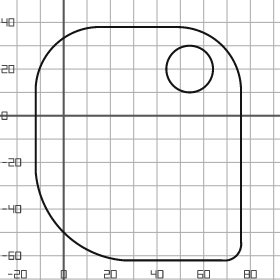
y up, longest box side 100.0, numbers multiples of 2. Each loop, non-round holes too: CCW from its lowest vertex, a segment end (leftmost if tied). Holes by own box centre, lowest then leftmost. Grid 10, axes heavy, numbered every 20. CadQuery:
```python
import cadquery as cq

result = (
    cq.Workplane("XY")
    .moveTo(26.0, -62.0)
    .lineTo(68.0, -62.0)
    .threePointArc((74.0, -60.0), (76.0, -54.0))
    .lineTo(76.0, 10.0)
    .threePointArc((68.0, 30.0), (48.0, 38.0))
    .lineTo(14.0, 38.0)
    .threePointArc((-4.0, 30.0), (-12.0, 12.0))
    .lineTo(-12.0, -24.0)
    .threePointArc((0.0, -50.0), (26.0, -62.0))
    .close()
    .moveTo(54.0, 20.0)
    .circle(10.0)
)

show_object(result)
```